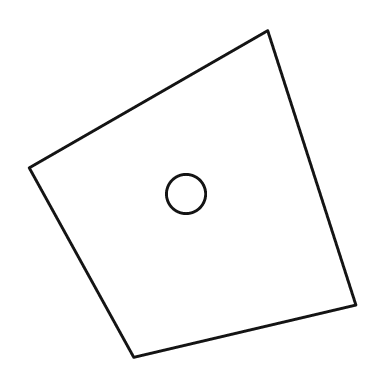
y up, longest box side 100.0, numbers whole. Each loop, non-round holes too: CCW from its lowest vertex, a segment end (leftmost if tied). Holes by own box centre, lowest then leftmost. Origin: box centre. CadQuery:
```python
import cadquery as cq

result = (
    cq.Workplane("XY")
    .moveTo(-18.0, -50.0)
    .lineTo(50.0, -34.0)
    .lineTo(23.0, 50.0)
    .lineTo(-50.0, 8.0)
    .close()
    .moveTo(-2.0, 0.0)
    .circle(6.0)
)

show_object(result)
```